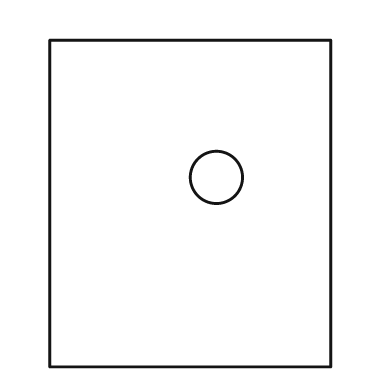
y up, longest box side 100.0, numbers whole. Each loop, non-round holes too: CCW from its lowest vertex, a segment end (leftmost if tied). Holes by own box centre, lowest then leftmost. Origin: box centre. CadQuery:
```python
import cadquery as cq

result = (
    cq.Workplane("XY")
    .moveTo(-43.0, -50.0)
    .lineTo(43.0, -50.0)
    .lineTo(43.0, 50.0)
    .lineTo(-43.0, 50.0)
    .close()
    .moveTo(8.0, 8.0)
    .circle(8.0)
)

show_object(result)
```